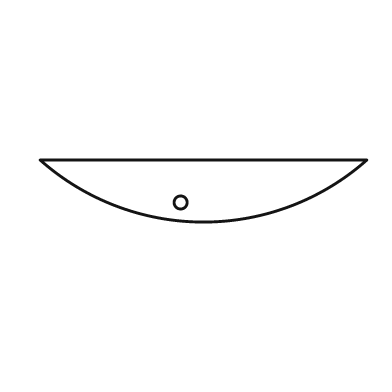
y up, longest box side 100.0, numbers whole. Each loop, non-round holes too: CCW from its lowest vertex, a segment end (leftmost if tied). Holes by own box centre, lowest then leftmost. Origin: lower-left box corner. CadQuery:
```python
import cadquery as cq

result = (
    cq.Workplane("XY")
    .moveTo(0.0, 19.0)
    .threePointArc((50.0, 0.0), (100.0, 19.0))
    .close()
    .moveTo(43.0, 6.0)
    .circle(2.0)
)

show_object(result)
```